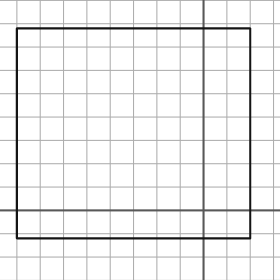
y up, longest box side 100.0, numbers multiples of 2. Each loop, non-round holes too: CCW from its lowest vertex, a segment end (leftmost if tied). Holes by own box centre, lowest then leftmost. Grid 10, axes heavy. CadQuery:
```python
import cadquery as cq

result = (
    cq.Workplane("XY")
    .moveTo(-80.0, -12.0)
    .lineTo(20.0, -12.0)
    .lineTo(20.0, 78.0)
    .lineTo(-80.0, 78.0)
    .close()
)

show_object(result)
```